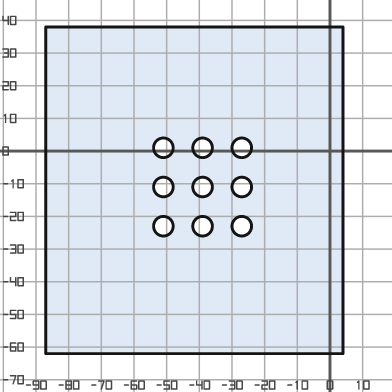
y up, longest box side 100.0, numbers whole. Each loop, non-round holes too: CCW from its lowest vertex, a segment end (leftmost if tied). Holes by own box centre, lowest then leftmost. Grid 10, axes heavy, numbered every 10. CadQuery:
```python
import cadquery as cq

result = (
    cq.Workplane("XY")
    .moveTo(-87.0, -62.0)
    .lineTo(4.0, -62.0)
    .lineTo(4.0, 38.0)
    .lineTo(-87.0, 38.0)
    .close()
    .moveTo(-51.0, -23.0)
    .circle(3.0)
    .moveTo(-39.0, -23.0)
    .circle(3.0)
    .moveTo(-27.0, -23.0)
    .circle(3.0)
    .moveTo(-51.0, -11.0)
    .circle(3.0)
    .moveTo(-39.0, -11.0)
    .circle(3.0)
    .moveTo(-27.0, -11.0)
    .circle(3.0)
    .moveTo(-51.0, 1.0)
    .circle(3.0)
    .moveTo(-39.0, 1.0)
    .circle(3.0)
    .moveTo(-27.0, 1.0)
    .circle(3.0)
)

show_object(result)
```